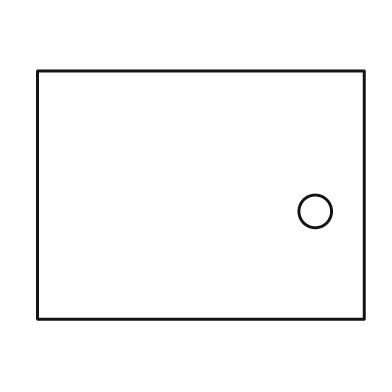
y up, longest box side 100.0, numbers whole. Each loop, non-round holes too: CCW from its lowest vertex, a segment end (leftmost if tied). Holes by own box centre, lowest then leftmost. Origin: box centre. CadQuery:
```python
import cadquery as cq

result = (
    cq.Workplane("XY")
    .moveTo(-50.0, -38.0)
    .lineTo(50.0, -38.0)
    .lineTo(50.0, 38.0)
    .lineTo(-50.0, 38.0)
    .close()
    .moveTo(35.0, -5.0)
    .circle(5.0)
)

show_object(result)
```